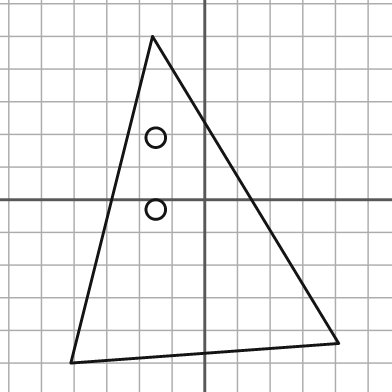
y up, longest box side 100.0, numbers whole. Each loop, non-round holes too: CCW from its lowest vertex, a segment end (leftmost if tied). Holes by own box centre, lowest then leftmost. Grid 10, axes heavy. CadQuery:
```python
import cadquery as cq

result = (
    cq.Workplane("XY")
    .moveTo(-41.0, -50.0)
    .lineTo(41.0, -44.0)
    .lineTo(-16.0, 50.0)
    .close()
    .moveTo(-15.0, -3.0)
    .circle(3.0)
    .moveTo(-15.0, 19.0)
    .circle(3.0)
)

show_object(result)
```